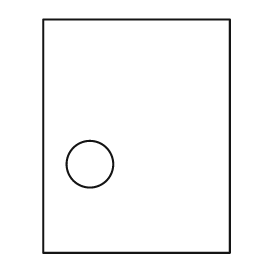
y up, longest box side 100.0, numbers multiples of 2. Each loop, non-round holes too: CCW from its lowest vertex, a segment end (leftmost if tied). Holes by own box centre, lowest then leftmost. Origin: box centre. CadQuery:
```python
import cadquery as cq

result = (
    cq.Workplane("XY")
    .moveTo(-40.0, -50.0)
    .lineTo(40.0, -50.0)
    .lineTo(40.0, 50.0)
    .lineTo(-40.0, 50.0)
    .close()
    .moveTo(-20.0, -12.0)
    .circle(10.0)
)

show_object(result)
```